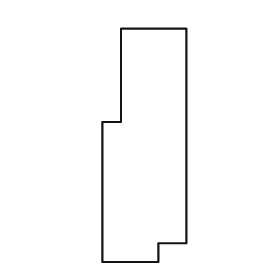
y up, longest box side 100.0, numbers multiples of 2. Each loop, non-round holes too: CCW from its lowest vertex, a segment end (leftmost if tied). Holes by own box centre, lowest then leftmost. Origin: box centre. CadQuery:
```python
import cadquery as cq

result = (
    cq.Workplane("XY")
    .moveTo(-18.0, -50.0)
    .lineTo(6.0, -50.0)
    .lineTo(6.0, -42.0)
    .lineTo(18.0, -42.0)
    .lineTo(18.0, 50.0)
    .lineTo(-10.0, 50.0)
    .lineTo(-10.0, 10.0)
    .lineTo(-18.0, 10.0)
    .close()
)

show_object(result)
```